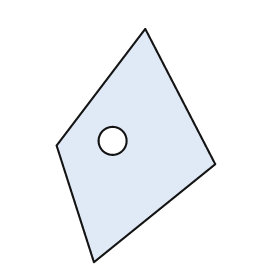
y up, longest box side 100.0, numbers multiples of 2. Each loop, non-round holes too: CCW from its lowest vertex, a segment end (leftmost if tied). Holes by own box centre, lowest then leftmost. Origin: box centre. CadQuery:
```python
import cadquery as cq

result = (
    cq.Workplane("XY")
    .moveTo(-18.0, -50.0)
    .lineTo(34.0, -8.0)
    .lineTo(4.0, 50.0)
    .lineTo(-34.0, 0.0)
    .close()
    .moveTo(-10.0, 2.0)
    .circle(6.0)
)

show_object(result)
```